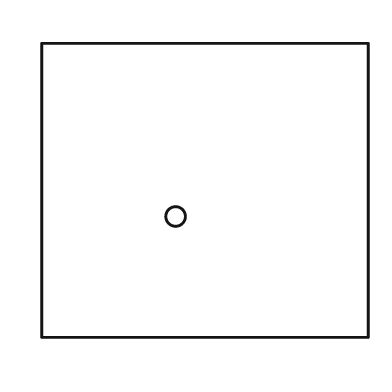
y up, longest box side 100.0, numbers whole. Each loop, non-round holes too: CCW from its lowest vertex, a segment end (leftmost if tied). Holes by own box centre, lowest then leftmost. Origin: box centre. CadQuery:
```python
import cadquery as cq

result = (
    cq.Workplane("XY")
    .moveTo(-50.0, -45.0)
    .lineTo(50.0, -45.0)
    .lineTo(50.0, 45.0)
    .lineTo(-50.0, 45.0)
    .close()
    .moveTo(-9.0, -8.0)
    .circle(3.0)
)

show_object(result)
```